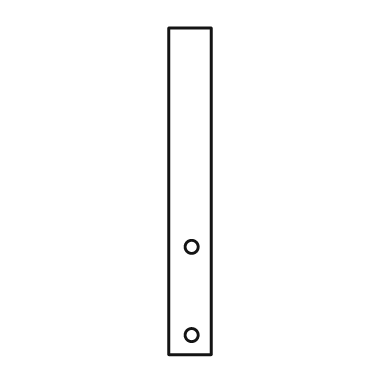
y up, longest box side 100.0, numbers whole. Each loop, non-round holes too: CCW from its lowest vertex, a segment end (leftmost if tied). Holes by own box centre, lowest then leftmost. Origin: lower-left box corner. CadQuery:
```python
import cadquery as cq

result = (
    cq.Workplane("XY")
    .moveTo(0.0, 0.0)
    .lineTo(13.0, 0.0)
    .lineTo(13.0, 100.0)
    .lineTo(0.0, 100.0)
    .close()
    .moveTo(7.0, 6.0)
    .circle(2.0)
    .moveTo(7.0, 33.0)
    .circle(2.0)
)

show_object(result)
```